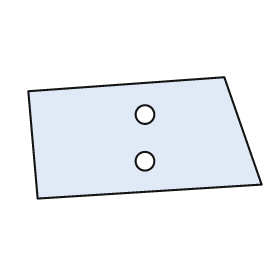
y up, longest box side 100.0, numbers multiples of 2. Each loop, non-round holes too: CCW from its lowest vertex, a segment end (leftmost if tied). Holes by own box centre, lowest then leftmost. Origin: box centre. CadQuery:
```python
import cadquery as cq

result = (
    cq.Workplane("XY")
    .moveTo(-46.0, -26.0)
    .lineTo(50.0, -20.0)
    .lineTo(34.0, 26.0)
    .lineTo(-50.0, 20.0)
    .close()
    .moveTo(0.0, -10.0)
    .circle(4.0)
    .moveTo(0.0, 10.0)
    .circle(4.0)
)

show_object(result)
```